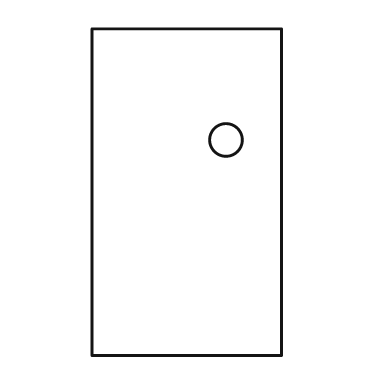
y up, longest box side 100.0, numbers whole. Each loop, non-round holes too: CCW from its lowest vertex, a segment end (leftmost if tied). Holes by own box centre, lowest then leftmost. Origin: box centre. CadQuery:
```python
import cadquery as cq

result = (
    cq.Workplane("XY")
    .moveTo(-29.0, -50.0)
    .lineTo(29.0, -50.0)
    .lineTo(29.0, 50.0)
    .lineTo(-29.0, 50.0)
    .close()
    .moveTo(12.0, 16.0)
    .circle(5.0)
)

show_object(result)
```